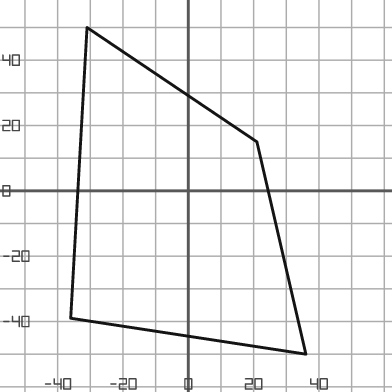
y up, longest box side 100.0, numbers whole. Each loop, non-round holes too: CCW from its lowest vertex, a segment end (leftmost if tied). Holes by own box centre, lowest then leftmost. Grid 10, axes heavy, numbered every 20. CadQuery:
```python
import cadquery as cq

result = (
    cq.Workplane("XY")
    .moveTo(36.0, -50.0)
    .lineTo(21.0, 15.0)
    .lineTo(-31.0, 50.0)
    .lineTo(-36.0, -39.0)
    .close()
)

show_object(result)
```